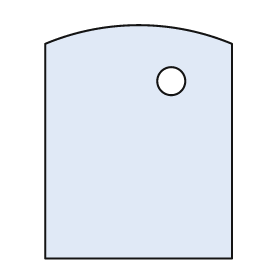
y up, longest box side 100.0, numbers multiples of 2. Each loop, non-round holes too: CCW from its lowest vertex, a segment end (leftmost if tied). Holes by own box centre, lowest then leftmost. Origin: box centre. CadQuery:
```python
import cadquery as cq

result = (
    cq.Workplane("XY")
    .moveTo(-40.0, -50.0)
    .lineTo(40.0, -50.0)
    .lineTo(40.0, 42.0)
    .threePointArc((0.0, 50.0), (-40.0, 42.0))
    .close()
    .moveTo(14.0, 26.0)
    .circle(6.0)
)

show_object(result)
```